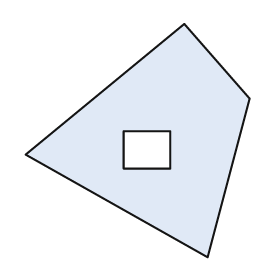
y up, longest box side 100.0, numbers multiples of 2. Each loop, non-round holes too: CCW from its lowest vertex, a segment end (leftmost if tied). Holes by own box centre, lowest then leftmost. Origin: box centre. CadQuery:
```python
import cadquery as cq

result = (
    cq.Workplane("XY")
    .moveTo(30.0, -50.0)
    .lineTo(48.0, 18.0)
    .lineTo(20.0, 50.0)
    .lineTo(-48.0, -6.0)
    .close()
    .moveTo(-6.0, -12.0)
    .lineTo(14.0, -12.0)
    .lineTo(14.0, 4.0)
    .lineTo(-6.0, 4.0)
    .close()
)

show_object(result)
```